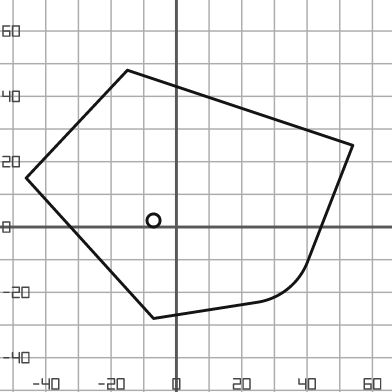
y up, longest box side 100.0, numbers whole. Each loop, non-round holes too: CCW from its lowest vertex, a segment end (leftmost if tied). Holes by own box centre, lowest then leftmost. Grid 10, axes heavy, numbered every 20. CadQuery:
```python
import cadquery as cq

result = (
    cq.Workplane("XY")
    .moveTo(-7.0, -28.0)
    .lineTo(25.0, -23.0)
    .threePointArc((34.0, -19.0), (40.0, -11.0))
    .lineTo(54.0, 25.0)
    .lineTo(-15.0, 48.0)
    .lineTo(-46.0, 15.0)
    .close()
    .moveTo(-7.0, 2.0)
    .circle(2.0)
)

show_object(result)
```